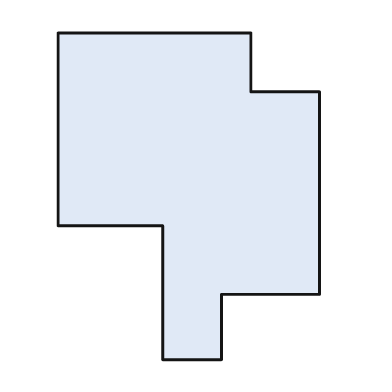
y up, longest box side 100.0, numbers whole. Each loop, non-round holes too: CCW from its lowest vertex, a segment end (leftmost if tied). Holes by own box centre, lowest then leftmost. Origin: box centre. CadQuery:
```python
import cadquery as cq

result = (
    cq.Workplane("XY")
    .moveTo(-8.0, -50.0)
    .lineTo(10.0, -50.0)
    .lineTo(10.0, -30.0)
    .lineTo(40.0, -30.0)
    .lineTo(40.0, 32.0)
    .lineTo(19.0, 32.0)
    .lineTo(19.0, 50.0)
    .lineTo(-40.0, 50.0)
    .lineTo(-40.0, -9.0)
    .lineTo(-8.0, -9.0)
    .close()
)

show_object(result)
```